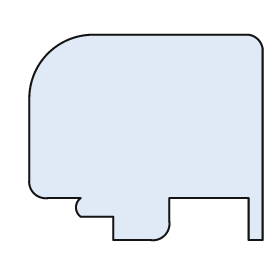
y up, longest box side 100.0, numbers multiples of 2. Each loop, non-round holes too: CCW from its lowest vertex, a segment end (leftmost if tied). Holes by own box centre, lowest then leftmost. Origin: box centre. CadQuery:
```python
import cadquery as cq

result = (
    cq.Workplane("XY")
    .moveTo(-14.0, -44.0)
    .lineTo(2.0, -44.0)
    .threePointArc((8.0, -42.0), (10.0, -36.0))
    .lineTo(10.0, -26.0)
    .lineTo(44.0, -26.0)
    .lineTo(44.0, -44.0)
    .lineTo(50.0, -44.0)
    .lineTo(50.0, 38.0)
    .threePointArc((48.0, 42.0), (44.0, 44.0))
    .lineTo(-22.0, 44.0)
    .threePointArc((-42.0, 36.0), (-50.0, 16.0))
    .lineTo(-50.0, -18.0)
    .threePointArc((-48.0, -24.0), (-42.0, -26.0))
    .lineTo(-28.0, -26.0)
    .threePointArc((-30.0, -30.0), (-28.0, -34.0))
    .lineTo(-14.0, -34.0)
    .close()
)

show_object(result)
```